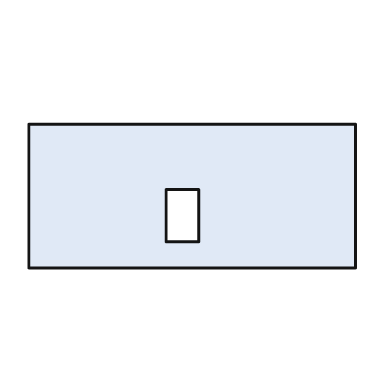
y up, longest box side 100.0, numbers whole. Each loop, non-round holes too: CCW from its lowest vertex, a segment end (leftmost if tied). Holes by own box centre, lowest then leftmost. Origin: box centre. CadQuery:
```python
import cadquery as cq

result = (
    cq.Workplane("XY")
    .moveTo(-50.0, -22.0)
    .lineTo(50.0, -22.0)
    .lineTo(50.0, 22.0)
    .lineTo(-50.0, 22.0)
    .close()
    .moveTo(-8.0, -14.0)
    .lineTo(2.0, -14.0)
    .lineTo(2.0, 2.0)
    .lineTo(-8.0, 2.0)
    .close()
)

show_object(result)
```